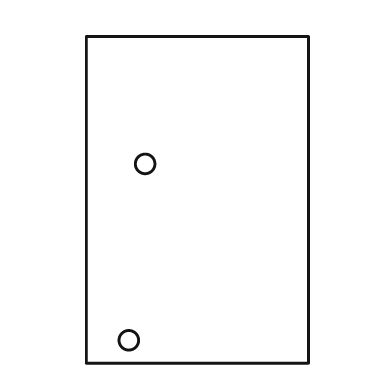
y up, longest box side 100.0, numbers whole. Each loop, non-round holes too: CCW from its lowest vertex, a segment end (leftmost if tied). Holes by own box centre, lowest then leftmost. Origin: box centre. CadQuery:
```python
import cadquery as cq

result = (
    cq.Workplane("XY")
    .moveTo(-34.0, -50.0)
    .lineTo(34.0, -50.0)
    .lineTo(34.0, 50.0)
    .lineTo(-34.0, 50.0)
    .close()
    .moveTo(-21.0, -43.0)
    .circle(3.0)
    .moveTo(-16.0, 11.0)
    .circle(3.0)
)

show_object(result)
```